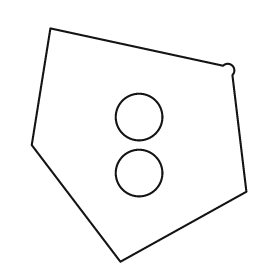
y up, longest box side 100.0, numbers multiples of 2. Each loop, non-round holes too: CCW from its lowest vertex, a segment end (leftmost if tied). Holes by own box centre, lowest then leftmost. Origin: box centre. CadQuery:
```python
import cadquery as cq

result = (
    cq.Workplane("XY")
    .moveTo(-8.0, -50.0)
    .lineTo(46.0, -20.0)
    .lineTo(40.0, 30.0)
    .threePointArc((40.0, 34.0), (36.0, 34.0))
    .lineTo(-38.0, 50.0)
    .lineTo(-46.0, 0.0)
    .close()
    .moveTo(0.0, -12.0)
    .circle(10.0)
    .moveTo(0.0, 12.0)
    .circle(10.0)
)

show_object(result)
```